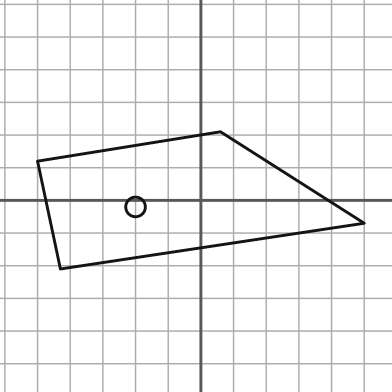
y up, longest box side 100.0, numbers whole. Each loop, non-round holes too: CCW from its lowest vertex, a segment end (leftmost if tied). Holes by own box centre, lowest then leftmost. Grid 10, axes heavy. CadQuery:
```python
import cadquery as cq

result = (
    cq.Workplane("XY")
    .moveTo(-43.0, -21.0)
    .lineTo(50.0, -7.0)
    .lineTo(6.0, 21.0)
    .lineTo(-50.0, 12.0)
    .close()
    .moveTo(-20.0, -2.0)
    .circle(3.0)
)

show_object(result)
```